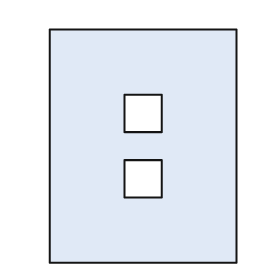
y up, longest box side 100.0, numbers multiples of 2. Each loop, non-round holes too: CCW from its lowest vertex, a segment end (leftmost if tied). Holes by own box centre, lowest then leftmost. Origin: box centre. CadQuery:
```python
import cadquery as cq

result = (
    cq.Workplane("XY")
    .moveTo(-40.0, -50.0)
    .lineTo(40.0, -50.0)
    .lineTo(40.0, 50.0)
    .lineTo(-40.0, 50.0)
    .close()
    .moveTo(-8.0, -22.0)
    .lineTo(8.0, -22.0)
    .lineTo(8.0, -6.0)
    .lineTo(-8.0, -6.0)
    .close()
    .moveTo(-8.0, 6.0)
    .lineTo(8.0, 6.0)
    .lineTo(8.0, 22.0)
    .lineTo(-8.0, 22.0)
    .close()
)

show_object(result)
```